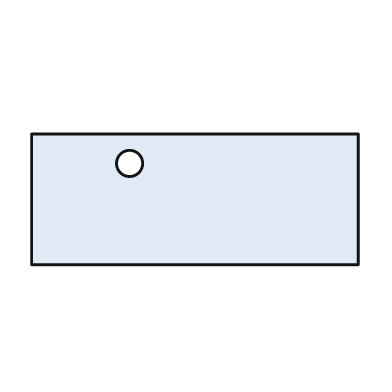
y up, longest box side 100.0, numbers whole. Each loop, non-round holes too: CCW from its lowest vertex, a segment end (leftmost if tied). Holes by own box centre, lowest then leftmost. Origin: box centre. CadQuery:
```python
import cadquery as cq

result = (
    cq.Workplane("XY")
    .moveTo(-50.0, -20.0)
    .lineTo(50.0, -20.0)
    .lineTo(50.0, 20.0)
    .lineTo(-50.0, 20.0)
    .close()
    .moveTo(-20.0, 11.0)
    .circle(4.0)
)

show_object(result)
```